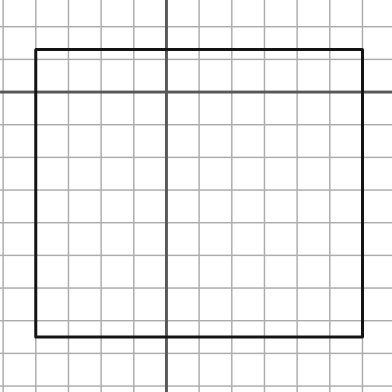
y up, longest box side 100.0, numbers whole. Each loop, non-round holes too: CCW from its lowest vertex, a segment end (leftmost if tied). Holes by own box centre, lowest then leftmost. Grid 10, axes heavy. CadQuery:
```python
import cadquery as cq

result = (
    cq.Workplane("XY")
    .moveTo(-40.0, -75.0)
    .lineTo(60.0, -75.0)
    .lineTo(60.0, 13.0)
    .lineTo(-40.0, 13.0)
    .close()
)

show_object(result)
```